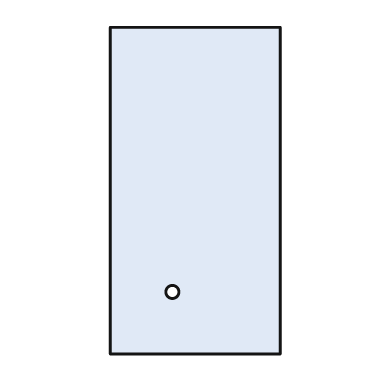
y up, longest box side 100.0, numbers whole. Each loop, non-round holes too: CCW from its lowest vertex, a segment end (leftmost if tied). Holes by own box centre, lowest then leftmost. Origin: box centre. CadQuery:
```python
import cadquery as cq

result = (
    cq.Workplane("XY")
    .moveTo(-26.0, -50.0)
    .lineTo(26.0, -50.0)
    .lineTo(26.0, 50.0)
    .lineTo(-26.0, 50.0)
    .close()
    .moveTo(-7.0, -31.0)
    .circle(2.0)
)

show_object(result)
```